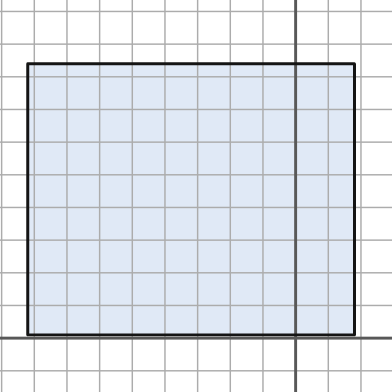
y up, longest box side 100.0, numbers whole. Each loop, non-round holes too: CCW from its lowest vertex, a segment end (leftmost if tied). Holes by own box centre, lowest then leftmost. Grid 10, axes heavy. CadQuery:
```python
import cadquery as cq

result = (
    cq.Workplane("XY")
    .moveTo(-82.0, 1.0)
    .lineTo(18.0, 1.0)
    .lineTo(18.0, 84.0)
    .lineTo(-82.0, 84.0)
    .close()
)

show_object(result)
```